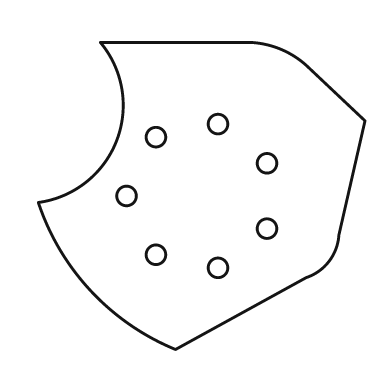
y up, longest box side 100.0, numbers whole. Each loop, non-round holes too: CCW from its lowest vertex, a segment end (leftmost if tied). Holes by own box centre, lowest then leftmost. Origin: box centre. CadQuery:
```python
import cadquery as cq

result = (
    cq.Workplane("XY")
    .moveTo(-8.0, -47.0)
    .lineTo(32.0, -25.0)
    .threePointArc((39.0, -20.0), (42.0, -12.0))
    .lineTo(50.0, 23.0)
    .lineTo(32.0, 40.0)
    .threePointArc((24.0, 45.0), (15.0, 47.0))
    .lineTo(-31.0, 47.0)
    .threePointArc((-26.0, 17.0), (-50.0, -2.0))
    .threePointArc((-34.0, -29.0), (-8.0, -47.0))
    .close()
    .moveTo(5.0, -22.0)
    .circle(3.0)
    .moveTo(-14.0, -18.0)
    .circle(3.0)
    .moveTo(20.0, -10.0)
    .circle(3.0)
    .moveTo(-23.0, 0.0)
    .circle(3.0)
    .moveTo(20.0, 10.0)
    .circle(3.0)
    .moveTo(-14.0, 18.0)
    .circle(3.0)
    .moveTo(5.0, 22.0)
    .circle(3.0)
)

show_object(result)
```